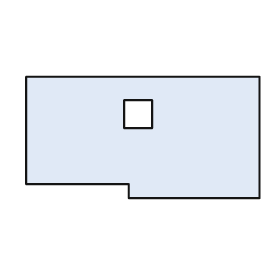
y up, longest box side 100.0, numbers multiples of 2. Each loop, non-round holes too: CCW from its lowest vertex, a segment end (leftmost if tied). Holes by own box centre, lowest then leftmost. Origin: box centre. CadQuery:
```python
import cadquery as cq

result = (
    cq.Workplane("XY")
    .moveTo(-6.0, -26.0)
    .lineTo(50.0, -26.0)
    .lineTo(50.0, 26.0)
    .lineTo(-50.0, 26.0)
    .lineTo(-50.0, -20.0)
    .lineTo(-6.0, -20.0)
    .close()
    .moveTo(-8.0, 4.0)
    .lineTo(4.0, 4.0)
    .lineTo(4.0, 16.0)
    .lineTo(-8.0, 16.0)
    .close()
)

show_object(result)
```